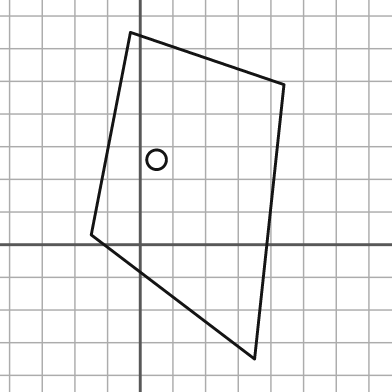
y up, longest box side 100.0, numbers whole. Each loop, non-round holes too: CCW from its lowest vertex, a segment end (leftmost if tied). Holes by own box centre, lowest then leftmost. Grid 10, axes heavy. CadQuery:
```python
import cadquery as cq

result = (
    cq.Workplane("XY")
    .moveTo(35.0, -35.0)
    .lineTo(44.0, 49.0)
    .lineTo(-3.0, 65.0)
    .lineTo(-15.0, 3.0)
    .close()
    .moveTo(5.0, 26.0)
    .circle(3.0)
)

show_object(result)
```